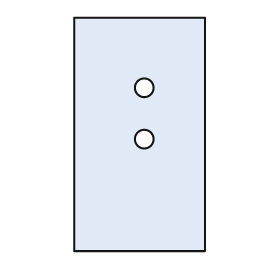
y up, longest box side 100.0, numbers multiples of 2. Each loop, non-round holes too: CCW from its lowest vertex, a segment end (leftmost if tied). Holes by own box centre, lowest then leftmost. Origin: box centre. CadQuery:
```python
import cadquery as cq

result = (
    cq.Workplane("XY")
    .moveTo(-28.0, -50.0)
    .lineTo(28.0, -50.0)
    .lineTo(28.0, 50.0)
    .lineTo(-28.0, 50.0)
    .close()
    .moveTo(2.0, -2.0)
    .circle(4.0)
    .moveTo(2.0, 20.0)
    .circle(4.0)
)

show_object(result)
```